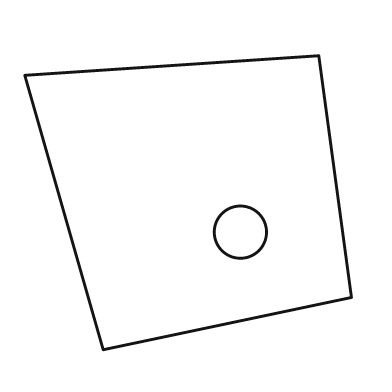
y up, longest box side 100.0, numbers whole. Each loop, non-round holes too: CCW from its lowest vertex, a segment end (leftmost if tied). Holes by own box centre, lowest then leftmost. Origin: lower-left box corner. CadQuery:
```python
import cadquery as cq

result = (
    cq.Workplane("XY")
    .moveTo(24.0, 0.0)
    .lineTo(100.0, 16.0)
    .lineTo(90.0, 90.0)
    .lineTo(0.0, 84.0)
    .close()
    .moveTo(66.0, 36.0)
    .circle(8.0)
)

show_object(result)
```